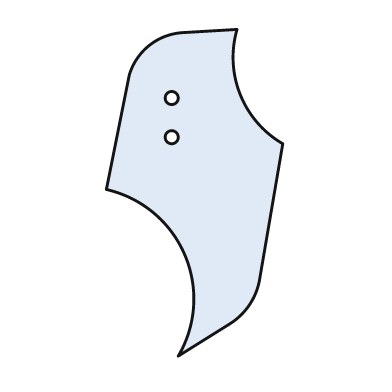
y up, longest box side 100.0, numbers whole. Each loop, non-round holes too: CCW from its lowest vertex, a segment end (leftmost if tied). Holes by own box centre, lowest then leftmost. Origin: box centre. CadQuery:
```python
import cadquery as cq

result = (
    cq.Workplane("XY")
    .moveTo(-5.0, -50.0)
    .lineTo(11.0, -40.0)
    .threePointArc((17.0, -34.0), (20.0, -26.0))
    .lineTo(27.0, 15.0)
    .threePointArc((14.0, 30.0), (13.0, 50.0))
    .lineTo(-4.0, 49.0)
    .threePointArc((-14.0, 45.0), (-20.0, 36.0))
    .lineTo(-27.0, 1.0)
    .threePointArc((-3.0, -19.0), (-5.0, -50.0))
    .close()
    .moveTo(-7.0, 17.0)
    .circle(2.0)
    .moveTo(-7.0, 29.0)
    .circle(2.0)
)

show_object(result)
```